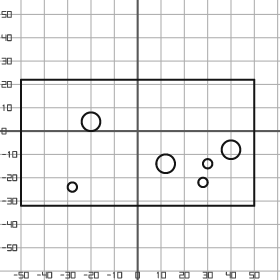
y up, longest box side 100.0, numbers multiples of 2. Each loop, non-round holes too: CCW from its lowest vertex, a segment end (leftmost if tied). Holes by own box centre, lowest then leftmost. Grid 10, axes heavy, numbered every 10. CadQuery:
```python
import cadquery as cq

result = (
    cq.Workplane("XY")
    .moveTo(-50.0, -32.0)
    .lineTo(50.0, -32.0)
    .lineTo(50.0, 22.0)
    .lineTo(-50.0, 22.0)
    .close()
    .moveTo(-28.0, -24.0)
    .circle(2.0)
    .moveTo(28.0, -22.0)
    .circle(2.0)
    .moveTo(12.0, -14.0)
    .circle(4.0)
    .moveTo(30.0, -14.0)
    .circle(2.0)
    .moveTo(40.0, -8.0)
    .circle(4.0)
    .moveTo(-20.0, 4.0)
    .circle(4.0)
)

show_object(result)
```